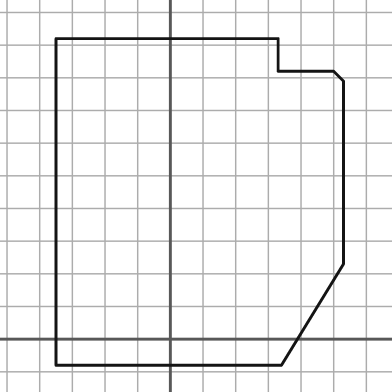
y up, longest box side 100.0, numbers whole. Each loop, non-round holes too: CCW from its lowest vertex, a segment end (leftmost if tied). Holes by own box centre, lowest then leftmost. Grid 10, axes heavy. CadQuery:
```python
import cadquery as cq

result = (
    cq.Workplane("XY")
    .moveTo(-35.0, -8.0)
    .lineTo(34.0, -8.0)
    .lineTo(53.0, 23.0)
    .lineTo(53.0, 79.0)
    .lineTo(50.0, 82.0)
    .lineTo(33.0, 82.0)
    .lineTo(33.0, 92.0)
    .lineTo(-35.0, 92.0)
    .close()
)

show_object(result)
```